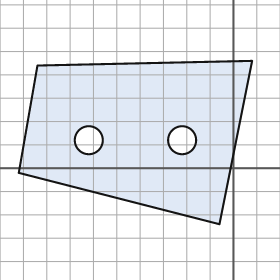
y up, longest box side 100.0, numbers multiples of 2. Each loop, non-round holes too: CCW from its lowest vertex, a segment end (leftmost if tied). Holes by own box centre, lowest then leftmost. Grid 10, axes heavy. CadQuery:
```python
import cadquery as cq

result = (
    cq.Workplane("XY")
    .moveTo(-6.0, -24.0)
    .lineTo(8.0, 46.0)
    .lineTo(-84.0, 44.0)
    .lineTo(-92.0, -2.0)
    .close()
    .moveTo(-62.0, 12.0)
    .circle(6.0)
    .moveTo(-22.0, 12.0)
    .circle(6.0)
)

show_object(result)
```